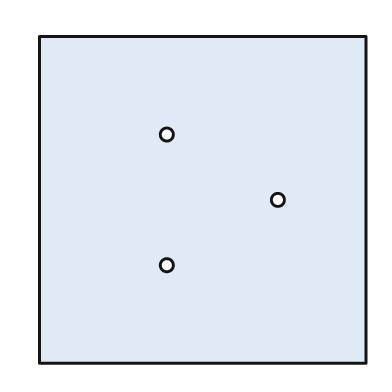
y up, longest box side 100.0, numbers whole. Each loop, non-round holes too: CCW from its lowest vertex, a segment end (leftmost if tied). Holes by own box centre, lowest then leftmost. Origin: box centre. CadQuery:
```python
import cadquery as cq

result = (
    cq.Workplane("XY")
    .moveTo(-50.0, -50.0)
    .lineTo(50.0, -50.0)
    .lineTo(50.0, 50.0)
    .lineTo(-50.0, 50.0)
    .close()
    .moveTo(-11.0, -20.0)
    .circle(2.0)
    .moveTo(23.0, 0.0)
    .circle(2.0)
    .moveTo(-11.0, 20.0)
    .circle(2.0)
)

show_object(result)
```